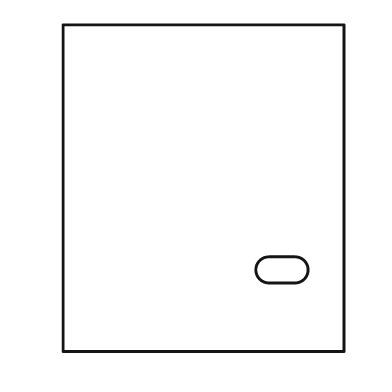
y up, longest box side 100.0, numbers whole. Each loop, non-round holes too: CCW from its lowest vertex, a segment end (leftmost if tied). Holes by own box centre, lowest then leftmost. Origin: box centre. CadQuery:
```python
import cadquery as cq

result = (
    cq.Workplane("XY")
    .moveTo(-43.0, -50.0)
    .lineTo(43.0, -50.0)
    .lineTo(43.0, 50.0)
    .lineTo(-43.0, 50.0)
    .close()
    .moveTo(20.0, -29.0)
    .lineTo(28.0, -29.0)
    .threePointArc((32.0, -25.0), (28.0, -21.0))
    .lineTo(20.0, -21.0)
    .threePointArc((16.0, -25.0), (20.0, -29.0))
    .close()
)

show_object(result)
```